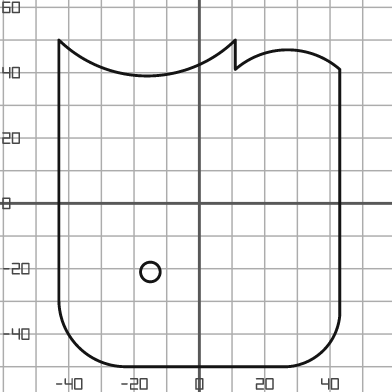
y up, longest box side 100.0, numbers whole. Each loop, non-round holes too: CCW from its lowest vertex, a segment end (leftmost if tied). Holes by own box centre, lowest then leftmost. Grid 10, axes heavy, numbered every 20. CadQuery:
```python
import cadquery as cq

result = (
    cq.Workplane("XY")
    .moveTo(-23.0, -50.0)
    .lineTo(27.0, -50.0)
    .threePointArc((38.0, -45.0), (43.0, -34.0))
    .lineTo(43.0, 41.0)
    .threePointArc((27.0, 47.0), (11.0, 41.0))
    .lineTo(11.0, 50.0)
    .threePointArc((-16.0, 39.0), (-43.0, 50.0))
    .lineTo(-43.0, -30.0)
    .threePointArc((-37.0, -44.0), (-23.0, -50.0))
    .close()
    .moveTo(-15.0, -21.0)
    .circle(3.0)
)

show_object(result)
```